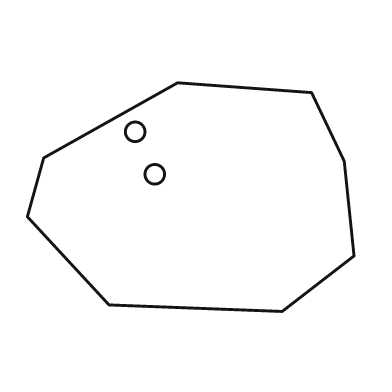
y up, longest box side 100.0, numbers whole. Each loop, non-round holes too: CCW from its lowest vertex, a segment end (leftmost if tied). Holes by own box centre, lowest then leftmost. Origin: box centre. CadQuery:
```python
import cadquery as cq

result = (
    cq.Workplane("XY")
    .moveTo(28.0, -35.0)
    .lineTo(50.0, -18.0)
    .lineTo(47.0, 11.0)
    .lineTo(37.0, 32.0)
    .lineTo(-4.0, 35.0)
    .lineTo(-45.0, 12.0)
    .lineTo(-50.0, -6.0)
    .lineTo(-25.0, -33.0)
    .close()
    .moveTo(-11.0, 7.0)
    .circle(3.0)
    .moveTo(-17.0, 20.0)
    .circle(3.0)
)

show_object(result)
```